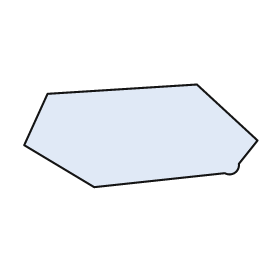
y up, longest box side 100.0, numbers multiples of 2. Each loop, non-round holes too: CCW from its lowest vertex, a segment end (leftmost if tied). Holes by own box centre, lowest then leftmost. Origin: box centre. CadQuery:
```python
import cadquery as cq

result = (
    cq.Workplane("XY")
    .moveTo(-20.0, -22.0)
    .lineTo(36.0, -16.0)
    .threePointArc((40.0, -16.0), (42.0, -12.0))
    .lineTo(50.0, -2.0)
    .lineTo(24.0, 22.0)
    .lineTo(-40.0, 18.0)
    .lineTo(-50.0, -4.0)
    .close()
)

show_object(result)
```